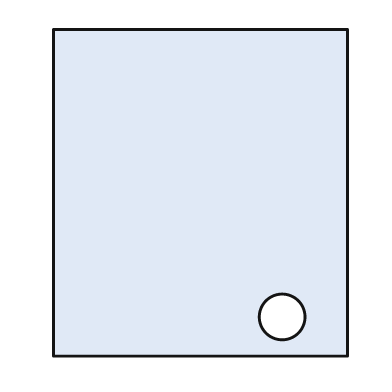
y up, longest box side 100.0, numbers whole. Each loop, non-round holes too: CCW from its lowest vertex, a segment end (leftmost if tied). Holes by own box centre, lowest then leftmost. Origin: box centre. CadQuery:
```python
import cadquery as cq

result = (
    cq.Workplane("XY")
    .moveTo(-45.0, -50.0)
    .lineTo(45.0, -50.0)
    .lineTo(45.0, 50.0)
    .lineTo(-45.0, 50.0)
    .close()
    .moveTo(25.0, -38.0)
    .circle(7.0)
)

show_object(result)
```